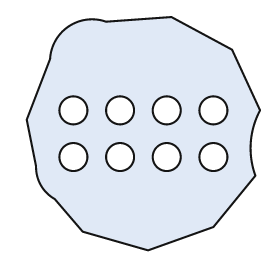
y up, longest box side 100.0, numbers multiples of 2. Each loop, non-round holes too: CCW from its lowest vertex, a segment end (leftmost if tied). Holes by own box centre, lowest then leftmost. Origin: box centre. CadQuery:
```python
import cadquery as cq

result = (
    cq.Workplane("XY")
    .moveTo(2.0, -50.0)
    .lineTo(30.0, -40.0)
    .lineTo(48.0, -18.0)
    .threePointArc((46.0, -4.0), (50.0, 10.0))
    .lineTo(38.0, 36.0)
    .lineTo(12.0, 50.0)
    .lineTo(-16.0, 48.0)
    .threePointArc((-32.0, 46.0), (-40.0, 32.0))
    .lineTo(-50.0, 6.0)
    .lineTo(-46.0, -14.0)
    .threePointArc((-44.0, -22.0), (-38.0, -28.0))
    .lineTo(-26.0, -42.0)
    .close()
    .moveTo(-30.0, -10.0)
    .circle(6.0)
    .moveTo(-10.0, -10.0)
    .circle(6.0)
    .moveTo(10.0, -10.0)
    .circle(6.0)
    .moveTo(30.0, -10.0)
    .circle(6.0)
    .moveTo(-30.0, 10.0)
    .circle(6.0)
    .moveTo(-10.0, 10.0)
    .circle(6.0)
    .moveTo(10.0, 10.0)
    .circle(6.0)
    .moveTo(30.0, 10.0)
    .circle(6.0)
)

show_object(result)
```